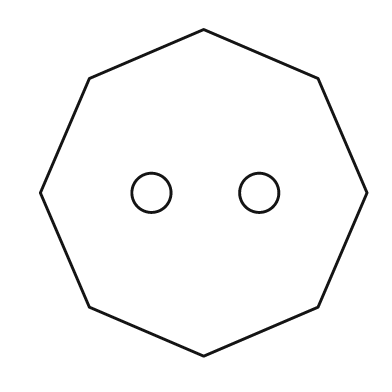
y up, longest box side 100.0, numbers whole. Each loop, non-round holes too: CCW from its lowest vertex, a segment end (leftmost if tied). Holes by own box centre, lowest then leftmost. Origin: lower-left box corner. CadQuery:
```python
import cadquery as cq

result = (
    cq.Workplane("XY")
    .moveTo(50.0, 0.0)
    .lineTo(85.0, 15.0)
    .lineTo(100.0, 50.0)
    .lineTo(85.0, 85.0)
    .lineTo(50.0, 100.0)
    .lineTo(15.0, 85.0)
    .lineTo(0.0, 50.0)
    .lineTo(15.0, 15.0)
    .close()
    .moveTo(34.0, 50.0)
    .circle(6.0)
    .moveTo(67.0, 50.0)
    .circle(6.0)
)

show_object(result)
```